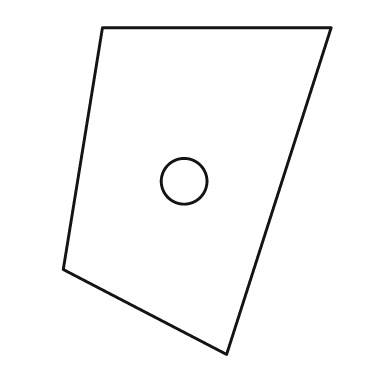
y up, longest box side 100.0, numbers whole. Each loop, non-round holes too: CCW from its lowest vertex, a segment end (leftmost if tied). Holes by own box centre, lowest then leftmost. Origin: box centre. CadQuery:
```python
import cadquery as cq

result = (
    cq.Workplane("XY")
    .moveTo(9.0, -50.0)
    .lineTo(41.0, 50.0)
    .lineTo(-29.0, 50.0)
    .lineTo(-41.0, -24.0)
    .close()
    .moveTo(-4.0, 3.0)
    .circle(7.0)
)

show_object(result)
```